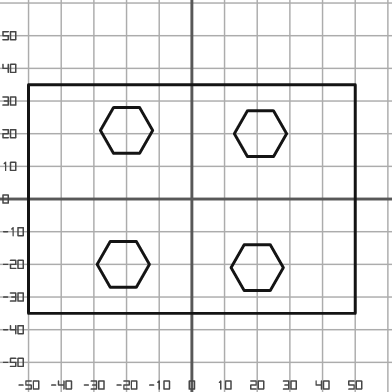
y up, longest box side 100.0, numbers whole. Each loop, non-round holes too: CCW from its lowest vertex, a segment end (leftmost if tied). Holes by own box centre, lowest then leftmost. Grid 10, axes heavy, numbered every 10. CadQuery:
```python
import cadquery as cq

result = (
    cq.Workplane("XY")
    .moveTo(-50.0, -35.0)
    .lineTo(50.0, -35.0)
    .lineTo(50.0, 35.0)
    .lineTo(-50.0, 35.0)
    .close()
    .moveTo(16.0, -28.0)
    .lineTo(24.0, -28.0)
    .lineTo(28.0, -21.0)
    .lineTo(24.0, -14.0)
    .lineTo(16.0, -14.0)
    .lineTo(12.0, -21.0)
    .close()
    .moveTo(-25.0, -27.0)
    .lineTo(-17.0, -27.0)
    .lineTo(-13.0, -20.0)
    .lineTo(-17.0, -13.0)
    .lineTo(-25.0, -13.0)
    .lineTo(-29.0, -20.0)
    .close()
    .moveTo(17.0, 13.0)
    .lineTo(25.0, 13.0)
    .lineTo(29.0, 20.0)
    .lineTo(25.0, 27.0)
    .lineTo(17.0, 27.0)
    .lineTo(13.0, 20.0)
    .close()
    .moveTo(-24.0, 14.0)
    .lineTo(-16.0, 14.0)
    .lineTo(-12.0, 21.0)
    .lineTo(-16.0, 28.0)
    .lineTo(-24.0, 28.0)
    .lineTo(-28.0, 21.0)
    .close()
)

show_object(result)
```